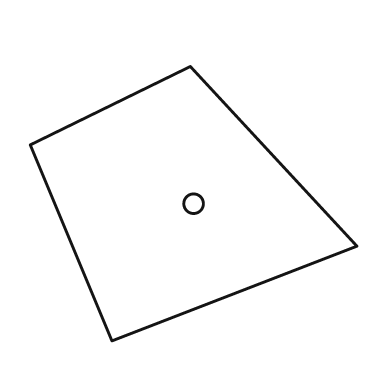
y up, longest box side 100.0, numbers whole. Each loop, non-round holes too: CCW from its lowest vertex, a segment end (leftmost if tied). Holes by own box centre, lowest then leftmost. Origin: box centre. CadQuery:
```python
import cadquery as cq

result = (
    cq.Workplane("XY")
    .moveTo(-25.0, -42.0)
    .lineTo(50.0, -13.0)
    .lineTo(-1.0, 42.0)
    .lineTo(-50.0, 18.0)
    .close()
    .moveTo(0.0, 0.0)
    .circle(3.0)
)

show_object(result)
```